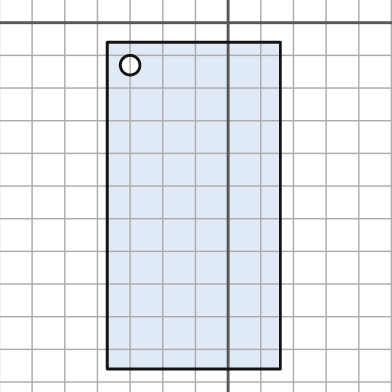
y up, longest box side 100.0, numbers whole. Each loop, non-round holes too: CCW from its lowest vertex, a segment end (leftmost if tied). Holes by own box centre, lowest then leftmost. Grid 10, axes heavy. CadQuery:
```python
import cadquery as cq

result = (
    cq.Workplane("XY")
    .moveTo(-37.0, -106.0)
    .lineTo(16.0, -106.0)
    .lineTo(16.0, -6.0)
    .lineTo(-37.0, -6.0)
    .close()
    .moveTo(-30.0, -13.0)
    .circle(3.0)
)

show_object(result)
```